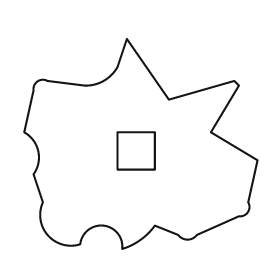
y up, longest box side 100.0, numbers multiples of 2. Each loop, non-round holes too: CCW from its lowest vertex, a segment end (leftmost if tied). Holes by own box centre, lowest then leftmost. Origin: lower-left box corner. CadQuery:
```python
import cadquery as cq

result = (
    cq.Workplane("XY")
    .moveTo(42.0, 0.0)
    .threePointArc((50.0, 4.0), (56.0, 10.0))
    .lineTo(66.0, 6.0)
    .threePointArc((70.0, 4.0), (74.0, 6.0))
    .lineTo(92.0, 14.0)
    .threePointArc((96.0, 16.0), (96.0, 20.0))
    .lineTo(100.0, 38.0)
    .lineTo(80.0, 50.0)
    .lineTo(92.0, 70.0)
    .lineTo(90.0, 72.0)
    .lineTo(62.0, 64.0)
    .lineTo(44.0, 90.0)
    .lineTo(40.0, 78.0)
    .threePointArc((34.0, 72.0), (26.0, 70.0))
    .lineTo(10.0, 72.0)
    .threePointArc((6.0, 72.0), (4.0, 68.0))
    .lineTo(0.0, 50.0)
    .threePointArc((6.0, 42.0), (4.0, 32.0))
    .lineTo(8.0, 20.0)
    .threePointArc((10.0, 6.0), (24.0, 2.0))
    .threePointArc((34.0, 10.0), (42.0, 0.0))
    .close()
    .moveTo(40.0, 34.0)
    .lineTo(56.0, 34.0)
    .lineTo(56.0, 50.0)
    .lineTo(40.0, 50.0)
    .close()
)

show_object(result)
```